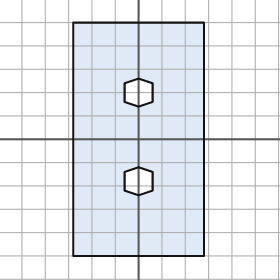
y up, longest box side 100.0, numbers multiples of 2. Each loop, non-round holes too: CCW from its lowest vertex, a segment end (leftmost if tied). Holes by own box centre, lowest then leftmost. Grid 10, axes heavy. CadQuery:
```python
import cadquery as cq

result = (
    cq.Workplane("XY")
    .moveTo(-28.0, -50.0)
    .lineTo(28.0, -50.0)
    .lineTo(28.0, 50.0)
    .lineTo(-28.0, 50.0)
    .close()
    .moveTo(0.0, -24.0)
    .lineTo(6.0, -22.0)
    .lineTo(6.0, -14.0)
    .lineTo(0.0, -12.0)
    .lineTo(-6.0, -14.0)
    .lineTo(-6.0, -22.0)
    .close()
    .moveTo(0.0, 14.0)
    .lineTo(6.0, 16.0)
    .lineTo(6.0, 24.0)
    .lineTo(0.0, 26.0)
    .lineTo(-6.0, 24.0)
    .lineTo(-6.0, 16.0)
    .close()
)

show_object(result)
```